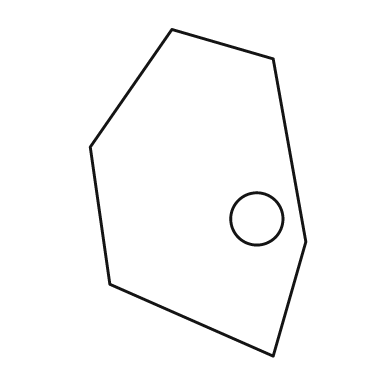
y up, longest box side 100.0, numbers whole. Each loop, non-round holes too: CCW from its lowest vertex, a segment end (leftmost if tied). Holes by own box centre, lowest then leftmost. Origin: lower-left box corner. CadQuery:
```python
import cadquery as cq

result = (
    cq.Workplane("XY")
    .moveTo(56.0, 0.0)
    .lineTo(66.0, 35.0)
    .lineTo(56.0, 91.0)
    .lineTo(25.0, 100.0)
    .lineTo(0.0, 64.0)
    .lineTo(6.0, 22.0)
    .close()
    .moveTo(51.0, 42.0)
    .circle(8.0)
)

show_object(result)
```